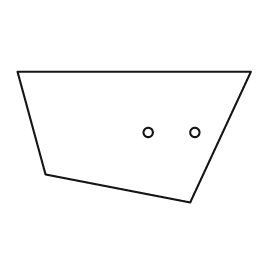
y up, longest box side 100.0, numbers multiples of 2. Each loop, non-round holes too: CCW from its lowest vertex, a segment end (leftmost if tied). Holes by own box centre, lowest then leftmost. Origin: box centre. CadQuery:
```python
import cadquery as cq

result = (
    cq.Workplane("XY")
    .moveTo(24.0, -28.0)
    .lineTo(50.0, 28.0)
    .lineTo(-50.0, 28.0)
    .lineTo(-38.0, -16.0)
    .close()
    .moveTo(6.0, 2.0)
    .circle(2.0)
    .moveTo(26.0, 2.0)
    .circle(2.0)
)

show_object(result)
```